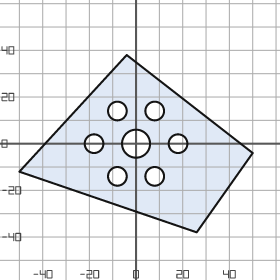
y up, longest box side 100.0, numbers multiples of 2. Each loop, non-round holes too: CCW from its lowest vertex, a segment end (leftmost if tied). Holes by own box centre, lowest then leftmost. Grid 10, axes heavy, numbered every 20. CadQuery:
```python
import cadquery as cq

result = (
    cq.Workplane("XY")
    .moveTo(26.0, -38.0)
    .lineTo(50.0, -4.0)
    .lineTo(-4.0, 38.0)
    .lineTo(-50.0, -12.0)
    .close()
    .moveTo(-8.0, -14.0)
    .circle(4.0)
    .moveTo(8.0, -14.0)
    .circle(4.0)
    .moveTo(-18.0, 0.0)
    .circle(4.0)
    .moveTo(0.0, 0.0)
    .circle(6.0)
    .moveTo(18.0, 0.0)
    .circle(4.0)
    .moveTo(-8.0, 14.0)
    .circle(4.0)
    .moveTo(8.0, 14.0)
    .circle(4.0)
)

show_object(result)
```